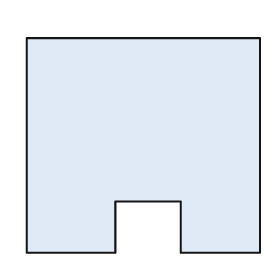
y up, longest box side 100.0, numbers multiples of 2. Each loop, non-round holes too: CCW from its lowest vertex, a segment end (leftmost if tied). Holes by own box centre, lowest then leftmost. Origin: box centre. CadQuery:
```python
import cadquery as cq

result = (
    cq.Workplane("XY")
    .moveTo(-50.0, -46.0)
    .lineTo(-12.0, -46.0)
    .lineTo(-12.0, -24.0)
    .lineTo(16.0, -24.0)
    .lineTo(16.0, -46.0)
    .lineTo(50.0, -46.0)
    .lineTo(50.0, 46.0)
    .lineTo(-50.0, 46.0)
    .close()
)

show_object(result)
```